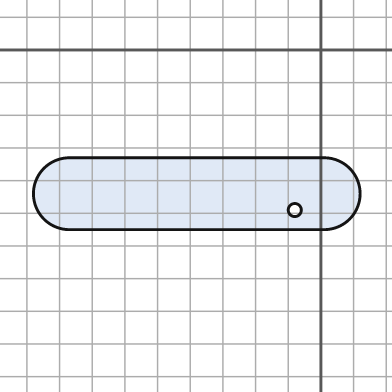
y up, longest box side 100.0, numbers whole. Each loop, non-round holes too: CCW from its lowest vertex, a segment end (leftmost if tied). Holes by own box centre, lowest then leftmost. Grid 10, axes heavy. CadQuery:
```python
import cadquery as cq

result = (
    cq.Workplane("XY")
    .moveTo(-77.0, -55.0)
    .lineTo(1.0, -55.0)
    .threePointArc((12.0, -44.0), (1.0, -33.0))
    .lineTo(-77.0, -33.0)
    .threePointArc((-88.0, -44.0), (-77.0, -55.0))
    .close()
    .moveTo(-8.0, -49.0)
    .circle(2.0)
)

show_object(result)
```